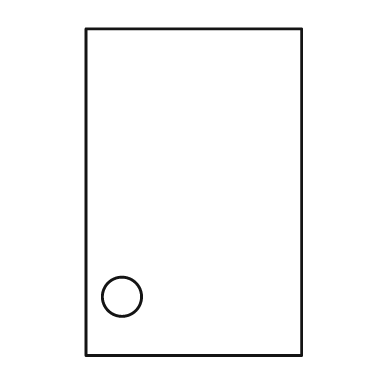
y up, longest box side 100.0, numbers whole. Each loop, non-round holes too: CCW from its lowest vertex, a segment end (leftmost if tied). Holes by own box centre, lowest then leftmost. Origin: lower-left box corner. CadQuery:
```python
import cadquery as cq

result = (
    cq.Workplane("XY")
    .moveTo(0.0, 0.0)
    .lineTo(66.0, 0.0)
    .lineTo(66.0, 100.0)
    .lineTo(0.0, 100.0)
    .close()
    .moveTo(11.0, 18.0)
    .circle(6.0)
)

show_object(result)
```